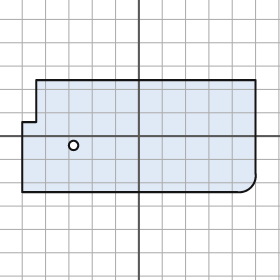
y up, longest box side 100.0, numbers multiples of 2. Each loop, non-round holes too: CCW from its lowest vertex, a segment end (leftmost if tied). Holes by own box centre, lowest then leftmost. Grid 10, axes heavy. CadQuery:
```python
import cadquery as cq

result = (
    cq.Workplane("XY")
    .moveTo(-50.0, -24.0)
    .lineTo(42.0, -24.0)
    .threePointArc((48.0, -22.0), (50.0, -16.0))
    .lineTo(50.0, 24.0)
    .lineTo(-44.0, 24.0)
    .lineTo(-44.0, 6.0)
    .lineTo(-50.0, 6.0)
    .close()
    .moveTo(-28.0, -4.0)
    .circle(2.0)
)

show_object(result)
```